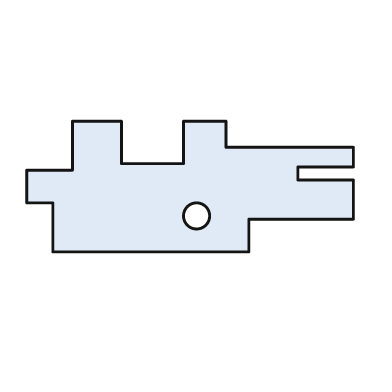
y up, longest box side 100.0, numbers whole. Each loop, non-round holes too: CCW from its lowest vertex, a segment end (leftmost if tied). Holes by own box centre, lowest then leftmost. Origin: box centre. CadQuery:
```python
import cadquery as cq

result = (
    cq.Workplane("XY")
    .moveTo(-42.0, -20.0)
    .lineTo(18.0, -20.0)
    .lineTo(18.0, -10.0)
    .lineTo(50.0, -10.0)
    .lineTo(50.0, 2.0)
    .lineTo(33.0, 2.0)
    .lineTo(33.0, 6.0)
    .lineTo(50.0, 6.0)
    .lineTo(50.0, 12.0)
    .lineTo(11.0, 12.0)
    .lineTo(11.0, 20.0)
    .lineTo(-2.0, 20.0)
    .lineTo(-2.0, 7.0)
    .lineTo(-21.0, 7.0)
    .lineTo(-21.0, 20.0)
    .lineTo(-36.0, 20.0)
    .lineTo(-36.0, 5.0)
    .lineTo(-50.0, 5.0)
    .lineTo(-50.0, -5.0)
    .lineTo(-42.0, -5.0)
    .close()
    .moveTo(2.0, -9.0)
    .circle(4.0)
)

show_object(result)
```